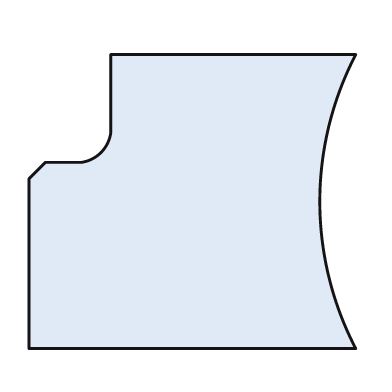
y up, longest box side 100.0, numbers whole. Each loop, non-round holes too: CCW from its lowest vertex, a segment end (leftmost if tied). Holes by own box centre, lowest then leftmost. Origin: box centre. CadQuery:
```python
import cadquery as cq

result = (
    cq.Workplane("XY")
    .moveTo(-50.0, -45.0)
    .lineTo(50.0, -45.0)
    .threePointArc((39.0, 0.0), (50.0, 45.0))
    .lineTo(-25.0, 45.0)
    .lineTo(-25.0, 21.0)
    .threePointArc((-28.0, 15.0), (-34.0, 12.0))
    .lineTo(-45.0, 12.0)
    .lineTo(-50.0, 7.0)
    .close()
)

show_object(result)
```